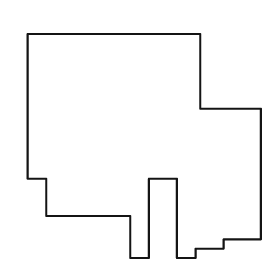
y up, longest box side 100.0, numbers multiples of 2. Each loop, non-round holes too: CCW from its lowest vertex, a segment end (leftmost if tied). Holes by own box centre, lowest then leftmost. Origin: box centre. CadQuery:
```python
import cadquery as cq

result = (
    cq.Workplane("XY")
    .moveTo(-6.0, -48.0)
    .lineTo(2.0, -48.0)
    .lineTo(2.0, -14.0)
    .lineTo(14.0, -14.0)
    .lineTo(14.0, -48.0)
    .lineTo(22.0, -48.0)
    .lineTo(22.0, -44.0)
    .lineTo(34.0, -44.0)
    .lineTo(34.0, -40.0)
    .lineTo(50.0, -40.0)
    .lineTo(50.0, 16.0)
    .lineTo(24.0, 16.0)
    .lineTo(24.0, 48.0)
    .lineTo(-50.0, 48.0)
    .lineTo(-50.0, -14.0)
    .lineTo(-42.0, -14.0)
    .lineTo(-42.0, -30.0)
    .lineTo(-6.0, -30.0)
    .close()
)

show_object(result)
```